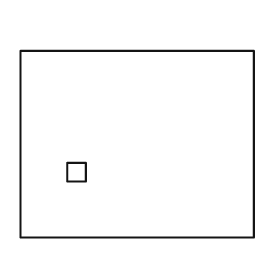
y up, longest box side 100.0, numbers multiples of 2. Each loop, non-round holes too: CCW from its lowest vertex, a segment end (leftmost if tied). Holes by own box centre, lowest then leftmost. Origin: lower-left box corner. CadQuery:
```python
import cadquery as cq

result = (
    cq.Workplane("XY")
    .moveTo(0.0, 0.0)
    .lineTo(100.0, 0.0)
    .lineTo(100.0, 80.0)
    .lineTo(0.0, 80.0)
    .close()
    .moveTo(20.0, 24.0)
    .lineTo(28.0, 24.0)
    .lineTo(28.0, 32.0)
    .lineTo(20.0, 32.0)
    .close()
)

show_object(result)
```